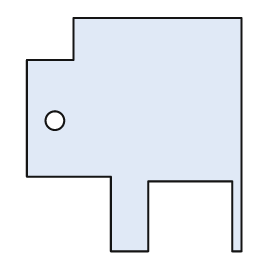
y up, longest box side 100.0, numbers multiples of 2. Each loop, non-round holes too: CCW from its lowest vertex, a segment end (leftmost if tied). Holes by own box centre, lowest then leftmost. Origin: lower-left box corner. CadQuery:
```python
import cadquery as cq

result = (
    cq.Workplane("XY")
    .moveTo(36.0, 0.0)
    .lineTo(52.0, 0.0)
    .lineTo(52.0, 30.0)
    .lineTo(88.0, 30.0)
    .lineTo(88.0, 0.0)
    .lineTo(92.0, 0.0)
    .lineTo(92.0, 100.0)
    .lineTo(20.0, 100.0)
    .lineTo(20.0, 82.0)
    .lineTo(0.0, 82.0)
    .lineTo(0.0, 32.0)
    .lineTo(36.0, 32.0)
    .close()
    .moveTo(12.0, 56.0)
    .circle(4.0)
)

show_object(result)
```